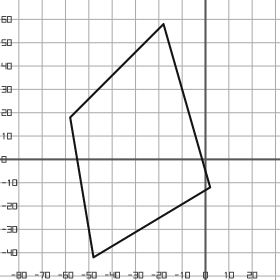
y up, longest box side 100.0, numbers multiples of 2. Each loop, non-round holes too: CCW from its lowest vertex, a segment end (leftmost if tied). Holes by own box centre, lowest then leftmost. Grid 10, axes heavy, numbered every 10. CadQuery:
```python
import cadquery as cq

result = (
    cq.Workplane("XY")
    .moveTo(-48.0, -42.0)
    .lineTo(2.0, -12.0)
    .lineTo(-18.0, 58.0)
    .lineTo(-58.0, 18.0)
    .close()
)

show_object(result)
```